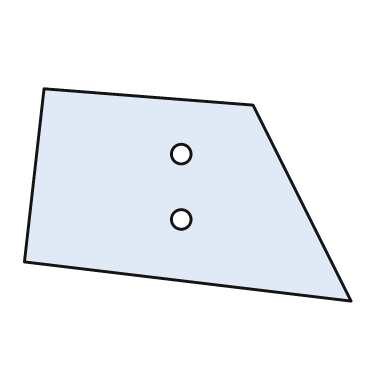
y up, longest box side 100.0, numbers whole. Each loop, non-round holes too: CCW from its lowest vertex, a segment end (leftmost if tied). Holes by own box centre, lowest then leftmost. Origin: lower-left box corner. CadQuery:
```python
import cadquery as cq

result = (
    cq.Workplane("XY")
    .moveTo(100.0, 0.0)
    .lineTo(70.0, 60.0)
    .lineTo(6.0, 65.0)
    .lineTo(0.0, 12.0)
    .close()
    .moveTo(48.0, 25.0)
    .circle(3.0)
    .moveTo(48.0, 45.0)
    .circle(3.0)
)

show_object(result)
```